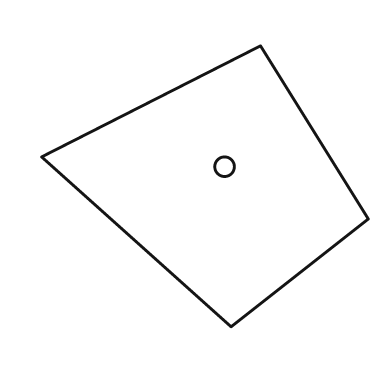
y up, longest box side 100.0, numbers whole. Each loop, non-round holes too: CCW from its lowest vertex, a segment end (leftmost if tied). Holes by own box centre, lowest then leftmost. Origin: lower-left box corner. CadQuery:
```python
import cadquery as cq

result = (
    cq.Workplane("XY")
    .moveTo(58.0, 0.0)
    .lineTo(100.0, 33.0)
    .lineTo(67.0, 86.0)
    .lineTo(0.0, 52.0)
    .close()
    .moveTo(56.0, 49.0)
    .circle(3.0)
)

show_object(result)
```